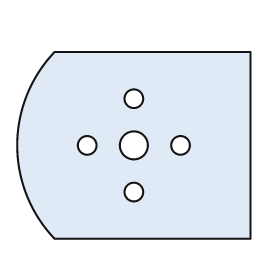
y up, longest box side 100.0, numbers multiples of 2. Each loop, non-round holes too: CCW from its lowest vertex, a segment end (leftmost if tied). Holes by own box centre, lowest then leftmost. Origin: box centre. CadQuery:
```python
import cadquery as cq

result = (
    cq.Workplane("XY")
    .moveTo(-34.0, -40.0)
    .lineTo(50.0, -40.0)
    .lineTo(50.0, 40.0)
    .lineTo(-34.0, 40.0)
    .threePointArc((-50.0, 0.0), (-34.0, -40.0))
    .close()
    .moveTo(0.0, -20.0)
    .circle(4.0)
    .moveTo(-20.0, 0.0)
    .circle(4.0)
    .moveTo(0.0, 0.0)
    .circle(6.0)
    .moveTo(20.0, 0.0)
    .circle(4.0)
    .moveTo(0.0, 20.0)
    .circle(4.0)
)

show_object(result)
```